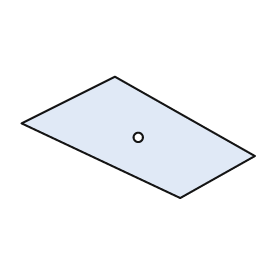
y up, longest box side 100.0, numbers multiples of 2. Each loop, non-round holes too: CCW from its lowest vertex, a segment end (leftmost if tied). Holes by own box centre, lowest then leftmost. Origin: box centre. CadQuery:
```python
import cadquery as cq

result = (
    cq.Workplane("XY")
    .moveTo(18.0, -26.0)
    .lineTo(50.0, -8.0)
    .lineTo(-10.0, 26.0)
    .lineTo(-50.0, 6.0)
    .close()
    .moveTo(0.0, 0.0)
    .circle(2.0)
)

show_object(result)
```